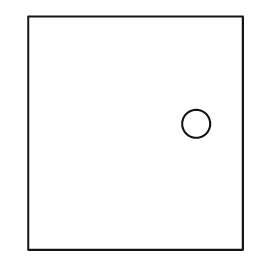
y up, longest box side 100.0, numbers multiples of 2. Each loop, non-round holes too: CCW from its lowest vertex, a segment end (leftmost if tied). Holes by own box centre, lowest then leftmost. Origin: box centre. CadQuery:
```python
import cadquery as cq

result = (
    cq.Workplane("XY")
    .moveTo(-46.0, -50.0)
    .lineTo(46.0, -50.0)
    .lineTo(46.0, 50.0)
    .lineTo(-46.0, 50.0)
    .close()
    .moveTo(26.0, 4.0)
    .circle(6.0)
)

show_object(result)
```